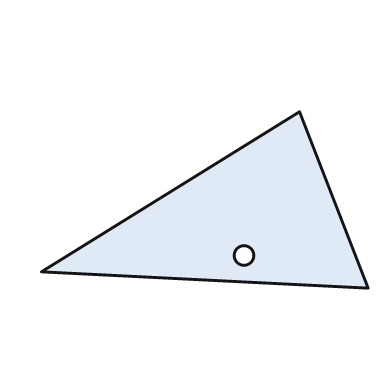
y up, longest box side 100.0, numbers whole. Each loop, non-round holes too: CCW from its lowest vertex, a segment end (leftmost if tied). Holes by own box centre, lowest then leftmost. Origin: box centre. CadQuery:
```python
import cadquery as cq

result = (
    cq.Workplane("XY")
    .moveTo(50.0, -27.0)
    .lineTo(29.0, 27.0)
    .lineTo(-50.0, -22.0)
    .close()
    .moveTo(12.0, -17.0)
    .circle(3.0)
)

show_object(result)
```